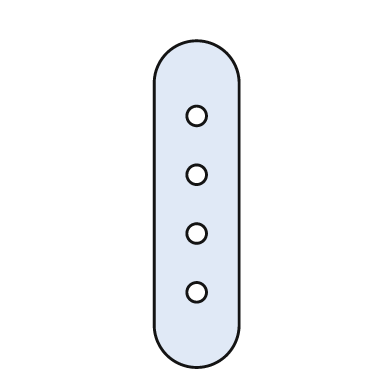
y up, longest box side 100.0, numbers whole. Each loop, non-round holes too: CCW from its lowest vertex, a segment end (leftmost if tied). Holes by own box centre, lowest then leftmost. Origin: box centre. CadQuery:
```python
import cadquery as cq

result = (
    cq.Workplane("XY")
    .moveTo(-13.0, -37.0)
    .threePointArc((0.0, -50.0), (13.0, -37.0))
    .lineTo(13.0, 37.0)
    .threePointArc((0.0, 50.0), (-13.0, 37.0))
    .close()
    .moveTo(0.0, -27.0)
    .circle(3.0)
    .moveTo(0.0, -9.0)
    .circle(3.0)
    .moveTo(0.0, 9.0)
    .circle(3.0)
    .moveTo(0.0, 27.0)
    .circle(3.0)
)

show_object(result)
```